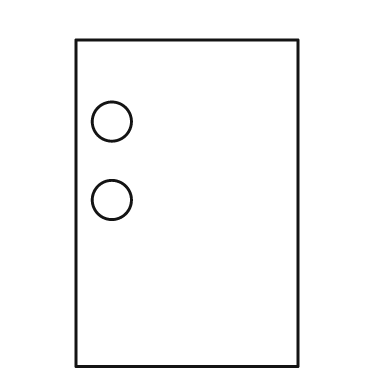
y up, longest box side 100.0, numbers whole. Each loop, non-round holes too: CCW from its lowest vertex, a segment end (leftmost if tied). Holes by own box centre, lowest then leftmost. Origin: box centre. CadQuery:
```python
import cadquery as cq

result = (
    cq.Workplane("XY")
    .moveTo(-34.0, -50.0)
    .lineTo(34.0, -50.0)
    .lineTo(34.0, 50.0)
    .lineTo(-34.0, 50.0)
    .close()
    .moveTo(-23.0, 1.0)
    .circle(6.0)
    .moveTo(-23.0, 25.0)
    .circle(6.0)
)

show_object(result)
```